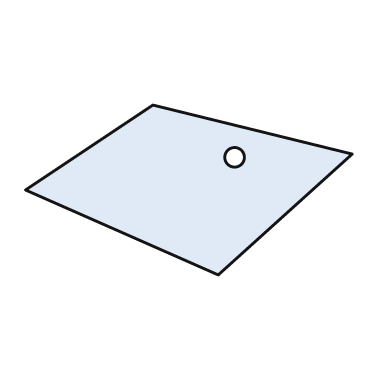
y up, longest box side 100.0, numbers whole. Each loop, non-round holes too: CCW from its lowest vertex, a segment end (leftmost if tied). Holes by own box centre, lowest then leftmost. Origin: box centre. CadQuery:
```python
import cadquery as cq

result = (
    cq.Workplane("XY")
    .moveTo(9.0, -26.0)
    .lineTo(50.0, 11.0)
    .lineTo(-11.0, 26.0)
    .lineTo(-50.0, 0.0)
    .close()
    .moveTo(14.0, 10.0)
    .circle(3.0)
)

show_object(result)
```